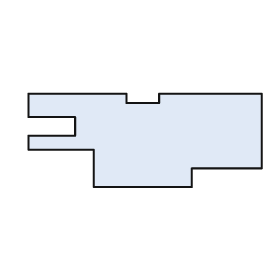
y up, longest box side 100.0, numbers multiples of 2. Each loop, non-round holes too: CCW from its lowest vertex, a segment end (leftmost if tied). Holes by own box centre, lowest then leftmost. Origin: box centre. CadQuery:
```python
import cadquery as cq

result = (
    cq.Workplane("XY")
    .moveTo(-22.0, -20.0)
    .lineTo(20.0, -20.0)
    .lineTo(20.0, -12.0)
    .lineTo(50.0, -12.0)
    .lineTo(50.0, 20.0)
    .lineTo(6.0, 20.0)
    .lineTo(6.0, 16.0)
    .lineTo(-8.0, 16.0)
    .lineTo(-8.0, 20.0)
    .lineTo(-50.0, 20.0)
    .lineTo(-50.0, 10.0)
    .lineTo(-30.0, 10.0)
    .lineTo(-30.0, 2.0)
    .lineTo(-50.0, 2.0)
    .lineTo(-50.0, -4.0)
    .lineTo(-22.0, -4.0)
    .close()
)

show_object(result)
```